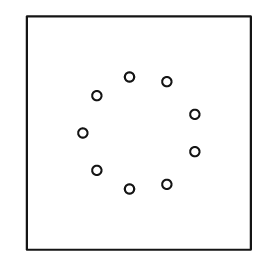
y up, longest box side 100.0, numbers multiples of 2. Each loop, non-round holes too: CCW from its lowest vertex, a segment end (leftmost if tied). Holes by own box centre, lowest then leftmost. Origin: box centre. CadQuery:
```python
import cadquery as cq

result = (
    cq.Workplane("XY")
    .moveTo(-48.0, -50.0)
    .lineTo(48.0, -50.0)
    .lineTo(48.0, 50.0)
    .lineTo(-48.0, 50.0)
    .close()
    .moveTo(-4.0, -24.0)
    .circle(2.0)
    .moveTo(12.0, -22.0)
    .circle(2.0)
    .moveTo(-18.0, -16.0)
    .circle(2.0)
    .moveTo(24.0, -8.0)
    .circle(2.0)
    .moveTo(-24.0, 0.0)
    .circle(2.0)
    .moveTo(24.0, 8.0)
    .circle(2.0)
    .moveTo(-18.0, 16.0)
    .circle(2.0)
    .moveTo(12.0, 22.0)
    .circle(2.0)
    .moveTo(-4.0, 24.0)
    .circle(2.0)
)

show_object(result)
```